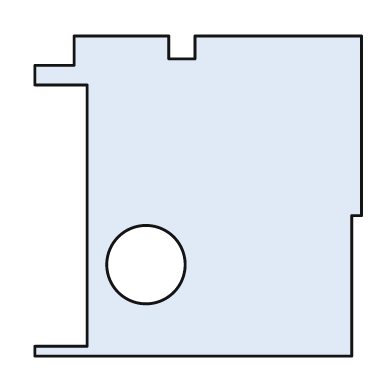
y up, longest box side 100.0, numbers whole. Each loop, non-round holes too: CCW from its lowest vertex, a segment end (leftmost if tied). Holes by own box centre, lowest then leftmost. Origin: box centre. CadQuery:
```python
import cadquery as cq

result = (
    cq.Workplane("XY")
    .moveTo(-50.0, -49.0)
    .lineTo(47.0, -49.0)
    .lineTo(47.0, -6.0)
    .lineTo(50.0, -6.0)
    .lineTo(50.0, 49.0)
    .lineTo(-1.0, 49.0)
    .lineTo(-1.0, 42.0)
    .lineTo(-9.0, 42.0)
    .lineTo(-9.0, 49.0)
    .lineTo(-38.0, 49.0)
    .lineTo(-38.0, 40.0)
    .lineTo(-50.0, 40.0)
    .lineTo(-50.0, 34.0)
    .lineTo(-34.0, 34.0)
    .lineTo(-34.0, -46.0)
    .lineTo(-50.0, -46.0)
    .close()
    .moveTo(-16.0, -21.0)
    .circle(12.0)
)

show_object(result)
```